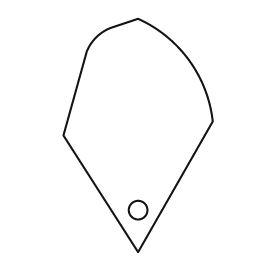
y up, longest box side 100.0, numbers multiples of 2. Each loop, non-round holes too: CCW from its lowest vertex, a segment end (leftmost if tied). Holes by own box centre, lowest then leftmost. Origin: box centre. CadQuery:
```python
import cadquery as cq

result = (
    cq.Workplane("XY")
    .moveTo(0.0, -50.0)
    .lineTo(32.0, 6.0)
    .threePointArc((22.0, 32.0), (0.0, 50.0))
    .lineTo(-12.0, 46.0)
    .threePointArc((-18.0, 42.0), (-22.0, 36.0))
    .lineTo(-32.0, 0.0)
    .close()
    .moveTo(0.0, -32.0)
    .circle(4.0)
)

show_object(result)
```